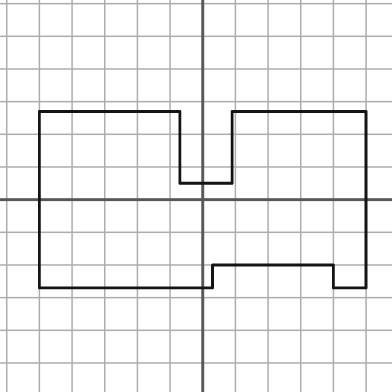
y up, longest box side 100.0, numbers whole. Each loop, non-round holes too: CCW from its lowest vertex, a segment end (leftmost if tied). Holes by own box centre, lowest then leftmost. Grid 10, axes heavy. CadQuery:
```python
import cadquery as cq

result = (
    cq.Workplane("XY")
    .moveTo(-50.0, -27.0)
    .lineTo(3.0, -27.0)
    .lineTo(3.0, -20.0)
    .lineTo(40.0, -20.0)
    .lineTo(40.0, -27.0)
    .lineTo(50.0, -27.0)
    .lineTo(50.0, 27.0)
    .lineTo(9.0, 27.0)
    .lineTo(9.0, 5.0)
    .lineTo(-7.0, 5.0)
    .lineTo(-7.0, 27.0)
    .lineTo(-50.0, 27.0)
    .close()
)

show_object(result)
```